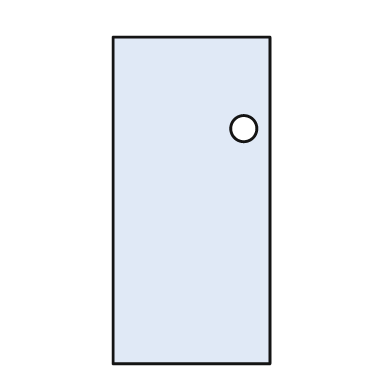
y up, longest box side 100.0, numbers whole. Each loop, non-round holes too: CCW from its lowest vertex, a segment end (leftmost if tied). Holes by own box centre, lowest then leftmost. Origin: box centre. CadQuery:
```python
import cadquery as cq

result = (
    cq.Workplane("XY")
    .moveTo(-24.0, -50.0)
    .lineTo(24.0, -50.0)
    .lineTo(24.0, 50.0)
    .lineTo(-24.0, 50.0)
    .close()
    .moveTo(16.0, 22.0)
    .circle(4.0)
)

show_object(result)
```